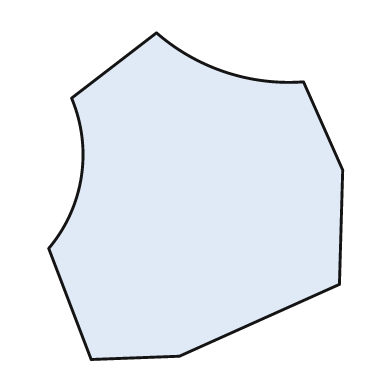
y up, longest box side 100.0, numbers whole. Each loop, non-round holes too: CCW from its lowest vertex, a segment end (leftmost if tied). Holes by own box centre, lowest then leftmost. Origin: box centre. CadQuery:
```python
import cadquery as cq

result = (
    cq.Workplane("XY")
    .moveTo(-32.0, -50.0)
    .lineTo(-5.0, -49.0)
    .lineTo(44.0, -27.0)
    .lineTo(45.0, 8.0)
    .lineTo(33.0, 35.0)
    .threePointArc((9.0, 38.0), (-12.0, 50.0))
    .lineTo(-38.0, 30.0)
    .threePointArc((-35.0, 6.0), (-45.0, -16.0))
    .close()
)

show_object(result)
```